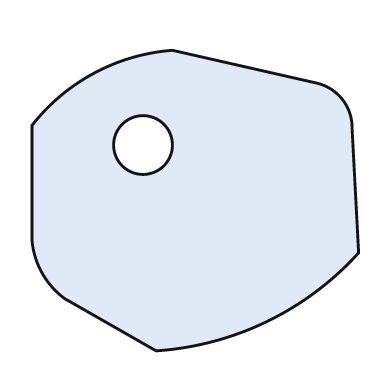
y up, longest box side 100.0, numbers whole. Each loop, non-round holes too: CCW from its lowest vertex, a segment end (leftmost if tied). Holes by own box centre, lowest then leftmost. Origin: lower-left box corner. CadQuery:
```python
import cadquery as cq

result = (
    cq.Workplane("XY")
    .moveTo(38.0, 0.0)
    .threePointArc((72.0, 9.0), (100.0, 30.0))
    .lineTo(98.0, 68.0)
    .threePointArc((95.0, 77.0), (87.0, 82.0))
    .lineTo(43.0, 92.0)
    .threePointArc((19.0, 85.0), (0.0, 69.0))
    .lineTo(0.0, 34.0)
    .threePointArc((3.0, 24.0), (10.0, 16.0))
    .close()
    .moveTo(34.0, 63.0)
    .circle(9.0)
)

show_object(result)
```